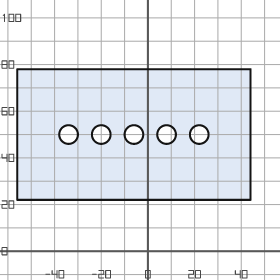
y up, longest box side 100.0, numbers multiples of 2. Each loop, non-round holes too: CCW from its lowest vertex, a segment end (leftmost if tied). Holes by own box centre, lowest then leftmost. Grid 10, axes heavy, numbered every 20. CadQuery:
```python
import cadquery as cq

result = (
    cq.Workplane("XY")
    .moveTo(-56.0, 22.0)
    .lineTo(44.0, 22.0)
    .lineTo(44.0, 78.0)
    .lineTo(-56.0, 78.0)
    .close()
    .moveTo(-34.0, 50.0)
    .circle(4.0)
    .moveTo(-20.0, 50.0)
    .circle(4.0)
    .moveTo(-6.0, 50.0)
    .circle(4.0)
    .moveTo(8.0, 50.0)
    .circle(4.0)
    .moveTo(22.0, 50.0)
    .circle(4.0)
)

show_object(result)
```